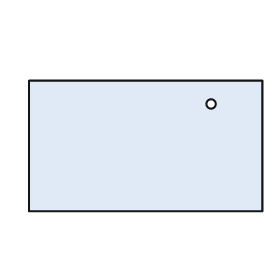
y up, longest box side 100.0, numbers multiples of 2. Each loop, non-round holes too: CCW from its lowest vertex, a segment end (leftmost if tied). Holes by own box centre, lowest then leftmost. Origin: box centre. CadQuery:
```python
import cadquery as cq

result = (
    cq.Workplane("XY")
    .moveTo(-50.0, -28.0)
    .lineTo(50.0, -28.0)
    .lineTo(50.0, 28.0)
    .lineTo(-50.0, 28.0)
    .close()
    .moveTo(28.0, 18.0)
    .circle(2.0)
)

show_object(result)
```